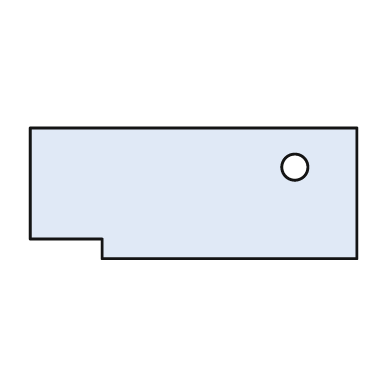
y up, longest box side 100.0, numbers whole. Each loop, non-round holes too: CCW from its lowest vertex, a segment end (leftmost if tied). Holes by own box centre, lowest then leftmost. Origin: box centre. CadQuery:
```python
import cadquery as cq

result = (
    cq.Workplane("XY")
    .moveTo(-28.0, -20.0)
    .lineTo(50.0, -20.0)
    .lineTo(50.0, 20.0)
    .lineTo(-50.0, 20.0)
    .lineTo(-50.0, -14.0)
    .lineTo(-28.0, -14.0)
    .close()
    .moveTo(31.0, 8.0)
    .circle(4.0)
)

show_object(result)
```